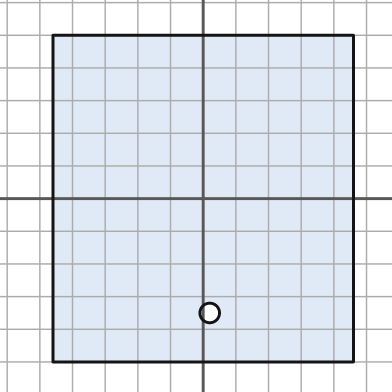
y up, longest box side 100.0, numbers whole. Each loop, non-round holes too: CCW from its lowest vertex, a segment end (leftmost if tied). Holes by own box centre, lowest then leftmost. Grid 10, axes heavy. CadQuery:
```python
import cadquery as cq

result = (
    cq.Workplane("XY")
    .moveTo(-46.0, -50.0)
    .lineTo(46.0, -50.0)
    .lineTo(46.0, 50.0)
    .lineTo(-46.0, 50.0)
    .close()
    .moveTo(2.0, -35.0)
    .circle(3.0)
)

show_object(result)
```